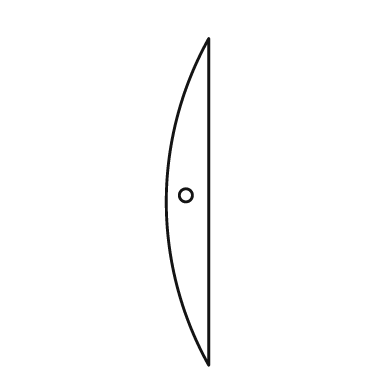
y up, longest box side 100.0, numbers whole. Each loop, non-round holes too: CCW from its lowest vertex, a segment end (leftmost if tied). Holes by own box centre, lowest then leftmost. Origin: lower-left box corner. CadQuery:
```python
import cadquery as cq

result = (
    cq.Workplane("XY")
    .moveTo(13.0, 0.0)
    .lineTo(13.0, 100.0)
    .threePointArc((0.0, 50.0), (13.0, 0.0))
    .close()
    .moveTo(6.0, 52.0)
    .circle(2.0)
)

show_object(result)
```